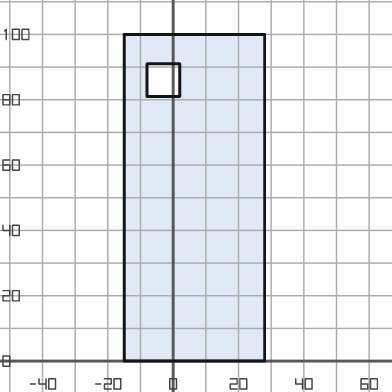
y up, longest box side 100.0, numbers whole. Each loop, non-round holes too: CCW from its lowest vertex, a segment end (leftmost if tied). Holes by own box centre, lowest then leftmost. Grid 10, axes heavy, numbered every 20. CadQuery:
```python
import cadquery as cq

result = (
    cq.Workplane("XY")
    .moveTo(-15.0, 0.0)
    .lineTo(28.0, 0.0)
    .lineTo(28.0, 100.0)
    .lineTo(-15.0, 100.0)
    .close()
    .moveTo(-8.0, 81.0)
    .lineTo(2.0, 81.0)
    .lineTo(2.0, 91.0)
    .lineTo(-8.0, 91.0)
    .close()
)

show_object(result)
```